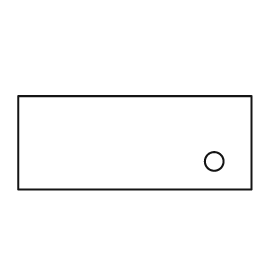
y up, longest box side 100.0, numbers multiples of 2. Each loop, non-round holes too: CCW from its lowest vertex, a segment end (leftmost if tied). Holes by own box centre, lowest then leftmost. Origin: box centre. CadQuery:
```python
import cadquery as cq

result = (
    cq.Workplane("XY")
    .moveTo(-50.0, -20.0)
    .lineTo(50.0, -20.0)
    .lineTo(50.0, 20.0)
    .lineTo(-50.0, 20.0)
    .close()
    .moveTo(34.0, -8.0)
    .circle(4.0)
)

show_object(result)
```